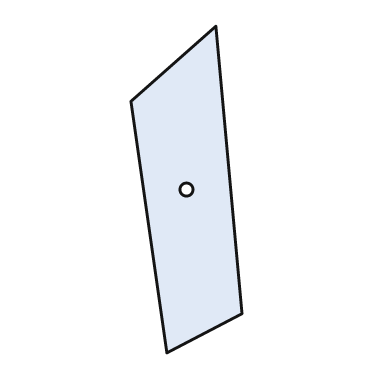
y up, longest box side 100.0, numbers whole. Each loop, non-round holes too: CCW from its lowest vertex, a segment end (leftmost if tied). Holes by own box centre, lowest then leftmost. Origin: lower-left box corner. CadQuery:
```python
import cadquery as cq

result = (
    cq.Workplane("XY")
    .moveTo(11.0, 0.0)
    .lineTo(34.0, 12.0)
    .lineTo(26.0, 100.0)
    .lineTo(0.0, 77.0)
    .close()
    .moveTo(17.0, 50.0)
    .circle(2.0)
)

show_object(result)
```